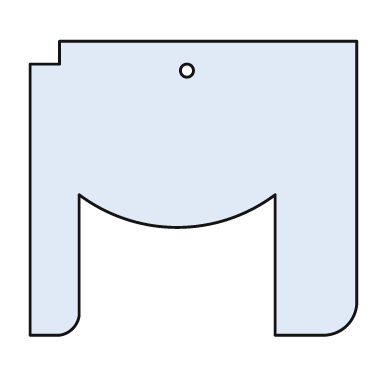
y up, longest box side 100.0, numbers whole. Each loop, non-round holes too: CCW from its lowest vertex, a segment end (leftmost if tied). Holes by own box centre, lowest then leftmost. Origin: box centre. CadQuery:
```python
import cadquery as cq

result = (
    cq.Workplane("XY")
    .moveTo(-50.0, -45.0)
    .lineTo(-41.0, -45.0)
    .threePointArc((-37.0, -43.0), (-35.0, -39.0))
    .lineTo(-35.0, -2.0)
    .threePointArc((-5.0, -12.0), (25.0, -2.0))
    .lineTo(25.0, -45.0)
    .lineTo(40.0, -45.0)
    .threePointArc((47.0, -42.0), (50.0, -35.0))
    .lineTo(50.0, 45.0)
    .lineTo(-41.0, 45.0)
    .lineTo(-41.0, 38.0)
    .lineTo(-50.0, 38.0)
    .close()
    .moveTo(-2.0, 36.0)
    .circle(2.0)
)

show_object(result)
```